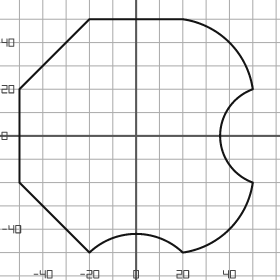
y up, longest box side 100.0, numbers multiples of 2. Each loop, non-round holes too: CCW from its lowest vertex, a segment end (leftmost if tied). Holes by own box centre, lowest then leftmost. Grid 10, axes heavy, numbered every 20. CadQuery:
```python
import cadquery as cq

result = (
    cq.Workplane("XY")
    .moveTo(-20.0, -50.0)
    .threePointArc((0.0, -42.0), (20.0, -50.0))
    .threePointArc((40.0, -40.0), (50.0, -20.0))
    .threePointArc((36.0, 0.0), (50.0, 20.0))
    .threePointArc((40.0, 40.0), (20.0, 50.0))
    .lineTo(-20.0, 50.0)
    .lineTo(-50.0, 20.0)
    .lineTo(-50.0, -20.0)
    .close()
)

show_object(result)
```